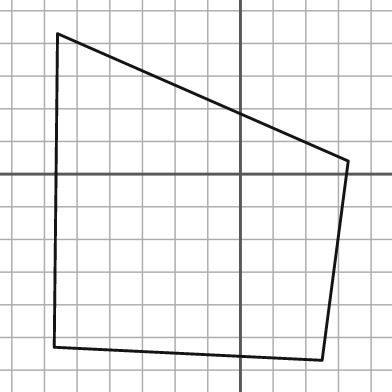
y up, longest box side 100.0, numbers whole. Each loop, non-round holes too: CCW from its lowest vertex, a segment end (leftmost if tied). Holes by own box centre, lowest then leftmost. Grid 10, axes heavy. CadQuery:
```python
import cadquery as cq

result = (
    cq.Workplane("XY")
    .moveTo(25.0, -57.0)
    .lineTo(33.0, 4.0)
    .lineTo(-56.0, 43.0)
    .lineTo(-57.0, -53.0)
    .close()
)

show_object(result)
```